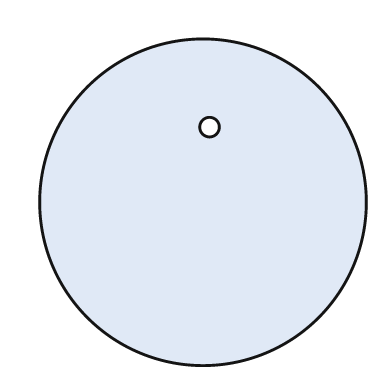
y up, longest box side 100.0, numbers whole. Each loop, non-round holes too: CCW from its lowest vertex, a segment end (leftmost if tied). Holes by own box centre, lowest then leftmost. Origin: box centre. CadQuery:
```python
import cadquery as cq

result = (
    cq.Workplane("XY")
    .moveTo(0.0, 0.0)
    .circle(50.0)
    .moveTo(2.0, 23.0)
    .circle(3.0)
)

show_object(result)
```